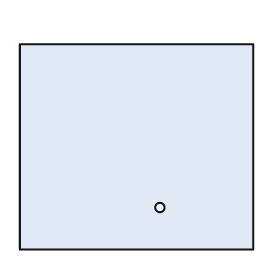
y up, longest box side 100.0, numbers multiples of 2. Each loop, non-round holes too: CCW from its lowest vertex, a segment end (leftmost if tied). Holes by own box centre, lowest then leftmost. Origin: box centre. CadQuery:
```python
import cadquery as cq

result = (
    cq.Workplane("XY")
    .moveTo(-50.0, -44.0)
    .lineTo(50.0, -44.0)
    .lineTo(50.0, 44.0)
    .lineTo(-50.0, 44.0)
    .close()
    .moveTo(10.0, -26.0)
    .circle(2.0)
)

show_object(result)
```